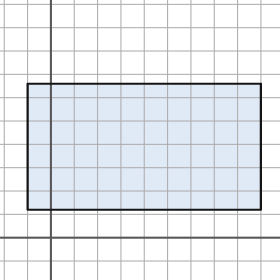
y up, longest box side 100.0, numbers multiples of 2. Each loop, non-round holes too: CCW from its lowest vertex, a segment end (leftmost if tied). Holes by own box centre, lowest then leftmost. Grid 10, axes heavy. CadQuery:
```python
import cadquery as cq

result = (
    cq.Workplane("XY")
    .moveTo(-10.0, 12.0)
    .lineTo(90.0, 12.0)
    .lineTo(90.0, 66.0)
    .lineTo(-10.0, 66.0)
    .close()
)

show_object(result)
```